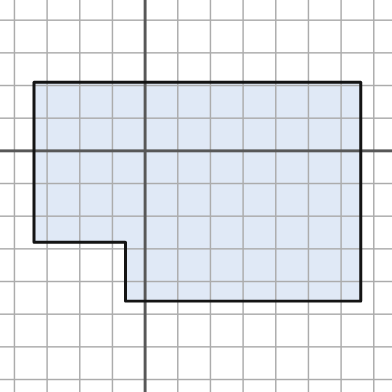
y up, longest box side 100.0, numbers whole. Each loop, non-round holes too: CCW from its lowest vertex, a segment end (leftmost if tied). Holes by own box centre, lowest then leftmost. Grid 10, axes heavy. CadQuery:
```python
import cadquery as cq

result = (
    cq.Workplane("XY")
    .moveTo(-6.0, -46.0)
    .lineTo(66.0, -46.0)
    .lineTo(66.0, 21.0)
    .lineTo(-34.0, 21.0)
    .lineTo(-34.0, -28.0)
    .lineTo(-6.0, -28.0)
    .close()
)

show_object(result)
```